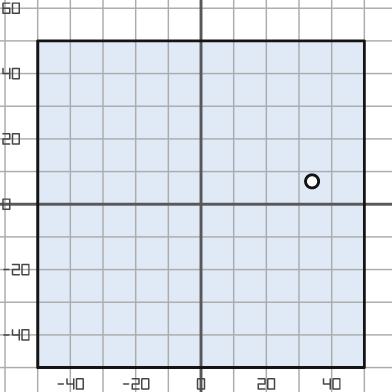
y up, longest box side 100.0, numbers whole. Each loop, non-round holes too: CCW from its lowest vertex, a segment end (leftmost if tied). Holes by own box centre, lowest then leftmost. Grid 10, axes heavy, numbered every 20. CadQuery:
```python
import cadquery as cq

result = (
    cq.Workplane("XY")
    .moveTo(-50.0, -50.0)
    .lineTo(50.0, -50.0)
    .lineTo(50.0, 50.0)
    .lineTo(-50.0, 50.0)
    .close()
    .moveTo(34.0, 7.0)
    .circle(2.0)
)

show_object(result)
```